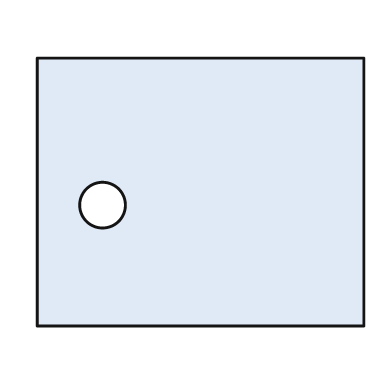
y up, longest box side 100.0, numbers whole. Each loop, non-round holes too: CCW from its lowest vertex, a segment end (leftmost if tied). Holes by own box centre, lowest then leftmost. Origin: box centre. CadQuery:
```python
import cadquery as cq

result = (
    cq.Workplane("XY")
    .moveTo(-50.0, -41.0)
    .lineTo(50.0, -41.0)
    .lineTo(50.0, 41.0)
    .lineTo(-50.0, 41.0)
    .close()
    .moveTo(-30.0, -4.0)
    .circle(7.0)
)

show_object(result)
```